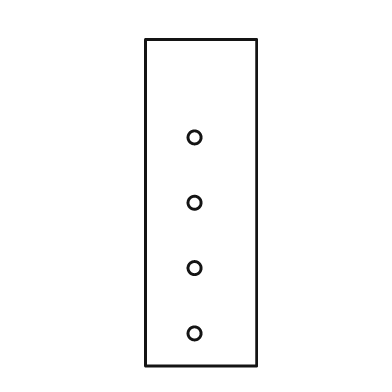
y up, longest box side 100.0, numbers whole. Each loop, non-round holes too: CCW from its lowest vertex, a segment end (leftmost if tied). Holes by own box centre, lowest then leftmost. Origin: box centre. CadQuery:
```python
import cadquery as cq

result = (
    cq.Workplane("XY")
    .moveTo(-17.0, -50.0)
    .lineTo(17.0, -50.0)
    .lineTo(17.0, 50.0)
    .lineTo(-17.0, 50.0)
    .close()
    .moveTo(-2.0, -40.0)
    .circle(2.0)
    .moveTo(-2.0, -20.0)
    .circle(2.0)
    .moveTo(-2.0, 0.0)
    .circle(2.0)
    .moveTo(-2.0, 20.0)
    .circle(2.0)
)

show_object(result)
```